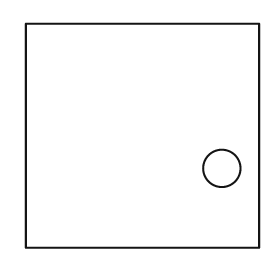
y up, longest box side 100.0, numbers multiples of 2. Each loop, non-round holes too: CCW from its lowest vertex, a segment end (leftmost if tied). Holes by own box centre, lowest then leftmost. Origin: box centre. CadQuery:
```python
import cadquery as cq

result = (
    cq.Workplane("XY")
    .moveTo(-50.0, -48.0)
    .lineTo(50.0, -48.0)
    .lineTo(50.0, 48.0)
    .lineTo(-50.0, 48.0)
    .close()
    .moveTo(34.0, -14.0)
    .circle(8.0)
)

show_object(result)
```